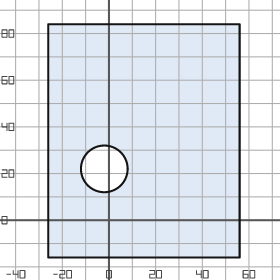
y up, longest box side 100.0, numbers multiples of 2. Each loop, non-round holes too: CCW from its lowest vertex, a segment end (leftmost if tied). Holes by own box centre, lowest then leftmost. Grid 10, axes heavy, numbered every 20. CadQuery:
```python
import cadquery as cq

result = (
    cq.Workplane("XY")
    .moveTo(-26.0, -16.0)
    .lineTo(56.0, -16.0)
    .lineTo(56.0, 84.0)
    .lineTo(-26.0, 84.0)
    .close()
    .moveTo(-2.0, 22.0)
    .circle(10.0)
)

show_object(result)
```